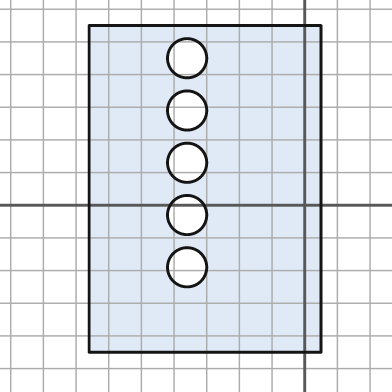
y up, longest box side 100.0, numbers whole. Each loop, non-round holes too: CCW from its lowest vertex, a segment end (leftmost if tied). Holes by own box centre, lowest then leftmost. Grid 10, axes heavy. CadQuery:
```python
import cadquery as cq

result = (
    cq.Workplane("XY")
    .moveTo(-66.0, -45.0)
    .lineTo(5.0, -45.0)
    .lineTo(5.0, 55.0)
    .lineTo(-66.0, 55.0)
    .close()
    .moveTo(-36.0, -19.0)
    .circle(6.0)
    .moveTo(-36.0, -3.0)
    .circle(6.0)
    .moveTo(-36.0, 13.0)
    .circle(6.0)
    .moveTo(-36.0, 29.0)
    .circle(6.0)
    .moveTo(-36.0, 45.0)
    .circle(6.0)
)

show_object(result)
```